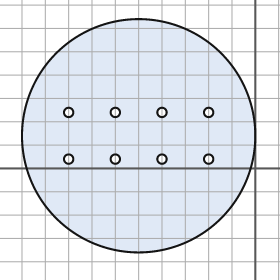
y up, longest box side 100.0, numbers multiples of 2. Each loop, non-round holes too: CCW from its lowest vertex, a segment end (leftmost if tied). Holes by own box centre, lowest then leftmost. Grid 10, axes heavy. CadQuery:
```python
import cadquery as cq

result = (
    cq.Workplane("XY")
    .moveTo(-50.0, 14.0)
    .circle(50.0)
    .moveTo(-80.0, 4.0)
    .circle(2.0)
    .moveTo(-60.0, 4.0)
    .circle(2.0)
    .moveTo(-40.0, 4.0)
    .circle(2.0)
    .moveTo(-20.0, 4.0)
    .circle(2.0)
    .moveTo(-80.0, 24.0)
    .circle(2.0)
    .moveTo(-60.0, 24.0)
    .circle(2.0)
    .moveTo(-40.0, 24.0)
    .circle(2.0)
    .moveTo(-20.0, 24.0)
    .circle(2.0)
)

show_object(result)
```